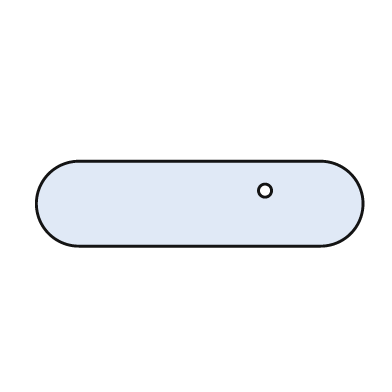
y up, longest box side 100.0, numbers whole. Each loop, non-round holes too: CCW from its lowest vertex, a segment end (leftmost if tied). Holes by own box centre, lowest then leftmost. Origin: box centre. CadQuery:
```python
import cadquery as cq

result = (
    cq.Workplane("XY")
    .moveTo(-37.0, -13.0)
    .lineTo(37.0, -13.0)
    .threePointArc((50.0, 0.0), (37.0, 13.0))
    .lineTo(-37.0, 13.0)
    .threePointArc((-50.0, 0.0), (-37.0, -13.0))
    .close()
    .moveTo(20.0, 4.0)
    .circle(2.0)
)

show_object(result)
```